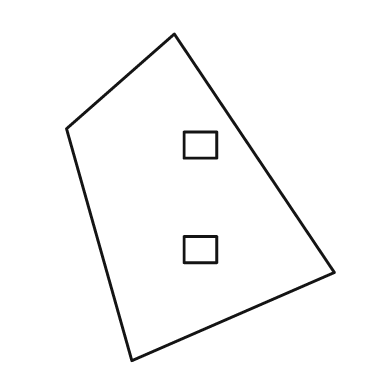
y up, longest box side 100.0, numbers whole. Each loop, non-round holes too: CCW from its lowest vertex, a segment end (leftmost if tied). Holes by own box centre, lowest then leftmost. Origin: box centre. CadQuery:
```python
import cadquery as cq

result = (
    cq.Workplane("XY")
    .moveTo(-21.0, -50.0)
    .lineTo(41.0, -23.0)
    .lineTo(-8.0, 50.0)
    .lineTo(-41.0, 21.0)
    .close()
    .moveTo(-5.0, -20.0)
    .lineTo(5.0, -20.0)
    .lineTo(5.0, -12.0)
    .lineTo(-5.0, -12.0)
    .close()
    .moveTo(-5.0, 12.0)
    .lineTo(5.0, 12.0)
    .lineTo(5.0, 20.0)
    .lineTo(-5.0, 20.0)
    .close()
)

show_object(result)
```